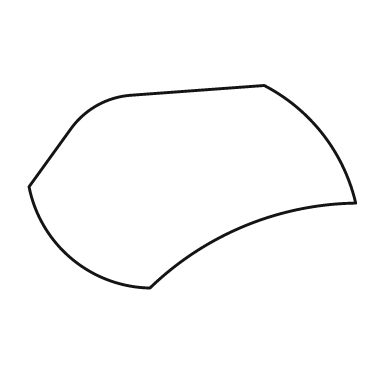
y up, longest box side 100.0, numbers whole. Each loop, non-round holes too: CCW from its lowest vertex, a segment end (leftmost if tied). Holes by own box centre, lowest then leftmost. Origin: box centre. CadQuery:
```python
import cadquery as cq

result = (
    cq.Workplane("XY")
    .moveTo(-13.0, -31.0)
    .threePointArc((16.0, -12.0), (50.0, -5.0))
    .threePointArc((40.0, 16.0), (22.0, 31.0))
    .lineTo(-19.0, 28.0)
    .threePointArc((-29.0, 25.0), (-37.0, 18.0))
    .lineTo(-50.0, 0.0)
    .threePointArc((-37.0, -22.0), (-13.0, -31.0))
    .close()
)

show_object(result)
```